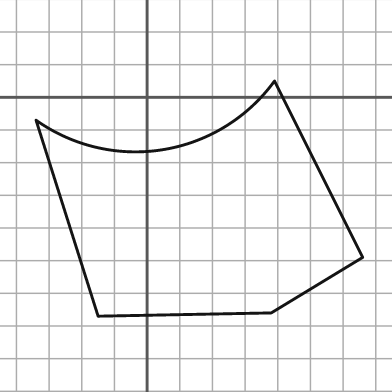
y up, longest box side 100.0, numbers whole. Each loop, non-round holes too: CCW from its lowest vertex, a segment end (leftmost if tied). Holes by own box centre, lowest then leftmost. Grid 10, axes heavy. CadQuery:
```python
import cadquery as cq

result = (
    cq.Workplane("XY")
    .moveTo(-15.0, -67.0)
    .lineTo(38.0, -66.0)
    .lineTo(66.0, -49.0)
    .lineTo(39.0, 5.0)
    .threePointArc((5.0, -16.0), (-34.0, -7.0))
    .close()
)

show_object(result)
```